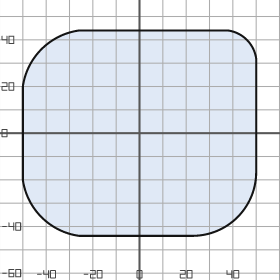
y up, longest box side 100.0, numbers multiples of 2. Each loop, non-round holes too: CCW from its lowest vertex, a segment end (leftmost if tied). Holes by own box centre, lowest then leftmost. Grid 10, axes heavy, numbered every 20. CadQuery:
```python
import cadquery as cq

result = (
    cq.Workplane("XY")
    .moveTo(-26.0, -44.0)
    .lineTo(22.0, -44.0)
    .threePointArc((42.0, -36.0), (50.0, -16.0))
    .lineTo(50.0, 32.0)
    .threePointArc((46.0, 40.0), (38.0, 44.0))
    .lineTo(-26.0, 44.0)
    .threePointArc((-42.0, 36.0), (-50.0, 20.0))
    .lineTo(-50.0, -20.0)
    .threePointArc((-42.0, -36.0), (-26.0, -44.0))
    .close()
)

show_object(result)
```